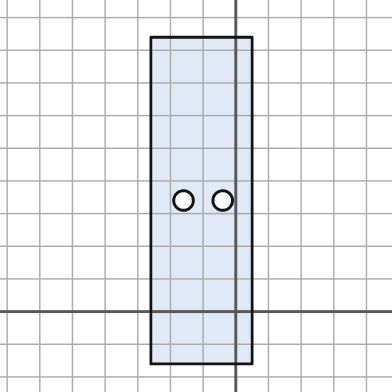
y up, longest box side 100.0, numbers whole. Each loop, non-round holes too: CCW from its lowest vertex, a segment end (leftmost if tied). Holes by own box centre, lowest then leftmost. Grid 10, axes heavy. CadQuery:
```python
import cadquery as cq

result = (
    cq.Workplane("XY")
    .moveTo(-26.0, -16.0)
    .lineTo(5.0, -16.0)
    .lineTo(5.0, 84.0)
    .lineTo(-26.0, 84.0)
    .close()
    .moveTo(-16.0, 34.0)
    .circle(3.0)
    .moveTo(-4.0, 34.0)
    .circle(3.0)
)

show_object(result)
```